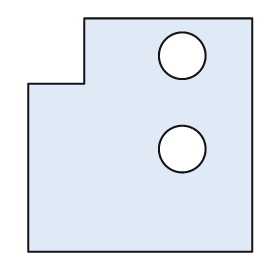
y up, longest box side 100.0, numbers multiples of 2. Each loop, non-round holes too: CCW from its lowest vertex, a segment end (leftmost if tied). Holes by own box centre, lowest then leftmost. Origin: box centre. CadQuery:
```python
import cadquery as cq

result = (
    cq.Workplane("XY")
    .moveTo(-48.0, -50.0)
    .lineTo(48.0, -50.0)
    .lineTo(48.0, 50.0)
    .lineTo(-24.0, 50.0)
    .lineTo(-24.0, 22.0)
    .lineTo(-48.0, 22.0)
    .close()
    .moveTo(18.0, -6.0)
    .circle(10.0)
    .moveTo(18.0, 34.0)
    .circle(10.0)
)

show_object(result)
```